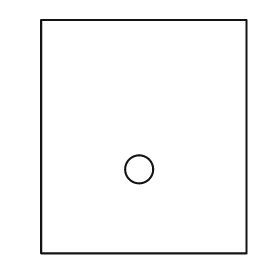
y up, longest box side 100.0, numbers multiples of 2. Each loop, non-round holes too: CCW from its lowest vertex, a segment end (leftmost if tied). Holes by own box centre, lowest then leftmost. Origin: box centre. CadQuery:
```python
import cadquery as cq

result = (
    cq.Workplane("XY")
    .moveTo(-44.0, -50.0)
    .lineTo(44.0, -50.0)
    .lineTo(44.0, 50.0)
    .lineTo(-44.0, 50.0)
    .close()
    .moveTo(-2.0, -14.0)
    .circle(6.0)
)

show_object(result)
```